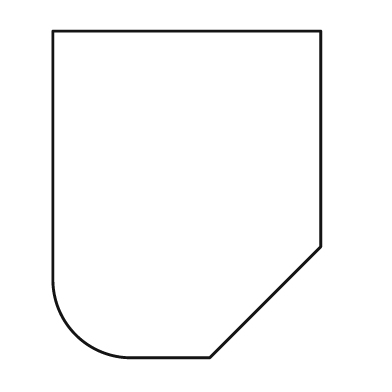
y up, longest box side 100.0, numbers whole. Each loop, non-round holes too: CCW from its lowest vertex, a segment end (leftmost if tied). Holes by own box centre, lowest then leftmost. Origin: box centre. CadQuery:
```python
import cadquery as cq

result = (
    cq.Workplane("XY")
    .moveTo(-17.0, -50.0)
    .lineTo(7.0, -50.0)
    .lineTo(41.0, -16.0)
    .lineTo(41.0, 50.0)
    .lineTo(-41.0, 50.0)
    .lineTo(-41.0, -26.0)
    .threePointArc((-34.0, -43.0), (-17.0, -50.0))
    .close()
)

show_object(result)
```